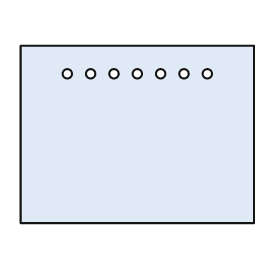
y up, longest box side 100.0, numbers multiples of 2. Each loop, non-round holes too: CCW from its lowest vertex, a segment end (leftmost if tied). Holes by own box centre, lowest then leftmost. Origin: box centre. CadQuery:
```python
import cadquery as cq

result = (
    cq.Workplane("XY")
    .moveTo(-50.0, -38.0)
    .lineTo(50.0, -38.0)
    .lineTo(50.0, 38.0)
    .lineTo(-50.0, 38.0)
    .close()
    .moveTo(-30.0, 26.0)
    .circle(2.0)
    .moveTo(-20.0, 26.0)
    .circle(2.0)
    .moveTo(-10.0, 26.0)
    .circle(2.0)
    .moveTo(0.0, 26.0)
    .circle(2.0)
    .moveTo(10.0, 26.0)
    .circle(2.0)
    .moveTo(20.0, 26.0)
    .circle(2.0)
    .moveTo(30.0, 26.0)
    .circle(2.0)
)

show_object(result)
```